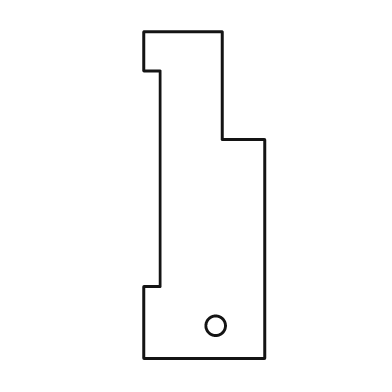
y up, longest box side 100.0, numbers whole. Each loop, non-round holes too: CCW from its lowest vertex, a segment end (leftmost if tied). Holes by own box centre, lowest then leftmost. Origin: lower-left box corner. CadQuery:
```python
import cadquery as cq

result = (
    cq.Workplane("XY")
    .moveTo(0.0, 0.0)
    .lineTo(37.0, 0.0)
    .lineTo(37.0, 67.0)
    .lineTo(24.0, 67.0)
    .lineTo(24.0, 100.0)
    .lineTo(0.0, 100.0)
    .lineTo(0.0, 88.0)
    .lineTo(5.0, 88.0)
    .lineTo(5.0, 22.0)
    .lineTo(0.0, 22.0)
    .close()
    .moveTo(22.0, 10.0)
    .circle(3.0)
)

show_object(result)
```